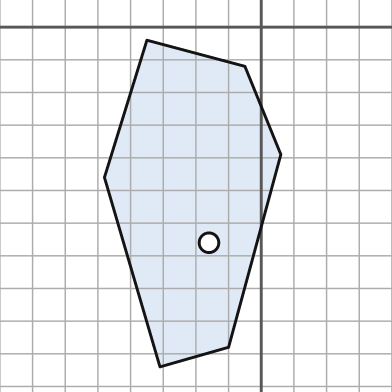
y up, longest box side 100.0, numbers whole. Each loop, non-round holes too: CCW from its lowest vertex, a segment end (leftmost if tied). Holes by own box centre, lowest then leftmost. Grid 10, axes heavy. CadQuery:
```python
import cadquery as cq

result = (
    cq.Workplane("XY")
    .moveTo(-31.0, -104.0)
    .lineTo(-10.0, -98.0)
    .lineTo(6.0, -39.0)
    .lineTo(-5.0, -12.0)
    .lineTo(-35.0, -4.0)
    .lineTo(-48.0, -46.0)
    .close()
    .moveTo(-16.0, -66.0)
    .circle(3.0)
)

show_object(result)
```